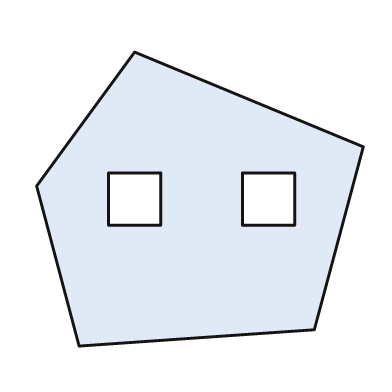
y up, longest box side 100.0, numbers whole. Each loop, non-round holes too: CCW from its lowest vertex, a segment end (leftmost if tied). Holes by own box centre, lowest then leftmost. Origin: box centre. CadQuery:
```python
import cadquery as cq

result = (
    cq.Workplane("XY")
    .moveTo(-37.0, -45.0)
    .lineTo(35.0, -40.0)
    .lineTo(50.0, 16.0)
    .lineTo(-20.0, 45.0)
    .lineTo(-50.0, 4.0)
    .close()
    .moveTo(-28.0, -8.0)
    .lineTo(-12.0, -8.0)
    .lineTo(-12.0, 8.0)
    .lineTo(-28.0, 8.0)
    .close()
    .moveTo(13.0, -8.0)
    .lineTo(29.0, -8.0)
    .lineTo(29.0, 8.0)
    .lineTo(13.0, 8.0)
    .close()
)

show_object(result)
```